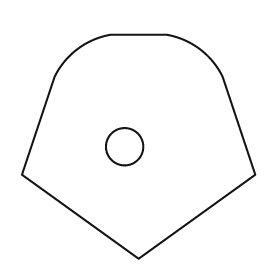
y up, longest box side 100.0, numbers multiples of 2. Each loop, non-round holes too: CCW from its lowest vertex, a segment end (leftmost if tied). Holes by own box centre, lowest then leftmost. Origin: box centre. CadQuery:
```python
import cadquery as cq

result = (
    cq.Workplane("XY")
    .moveTo(0.0, -48.0)
    .lineTo(50.0, -12.0)
    .lineTo(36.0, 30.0)
    .threePointArc((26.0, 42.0), (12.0, 48.0))
    .lineTo(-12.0, 48.0)
    .threePointArc((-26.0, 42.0), (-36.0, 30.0))
    .lineTo(-50.0, -12.0)
    .close()
    .moveTo(-6.0, 0.0)
    .circle(8.0)
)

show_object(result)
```